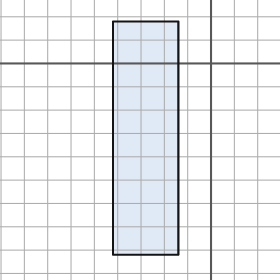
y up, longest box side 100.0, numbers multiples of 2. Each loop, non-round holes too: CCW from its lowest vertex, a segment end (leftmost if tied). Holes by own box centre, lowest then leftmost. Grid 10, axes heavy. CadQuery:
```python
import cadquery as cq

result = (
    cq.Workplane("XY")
    .moveTo(-42.0, -82.0)
    .lineTo(-14.0, -82.0)
    .lineTo(-14.0, 18.0)
    .lineTo(-42.0, 18.0)
    .close()
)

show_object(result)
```